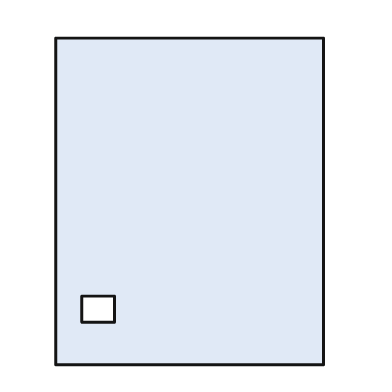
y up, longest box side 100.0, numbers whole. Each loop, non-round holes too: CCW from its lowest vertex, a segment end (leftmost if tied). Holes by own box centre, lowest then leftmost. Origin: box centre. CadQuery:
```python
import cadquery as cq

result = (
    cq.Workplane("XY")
    .moveTo(-41.0, -50.0)
    .lineTo(41.0, -50.0)
    .lineTo(41.0, 50.0)
    .lineTo(-41.0, 50.0)
    .close()
    .moveTo(-33.0, -37.0)
    .lineTo(-23.0, -37.0)
    .lineTo(-23.0, -29.0)
    .lineTo(-33.0, -29.0)
    .close()
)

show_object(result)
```